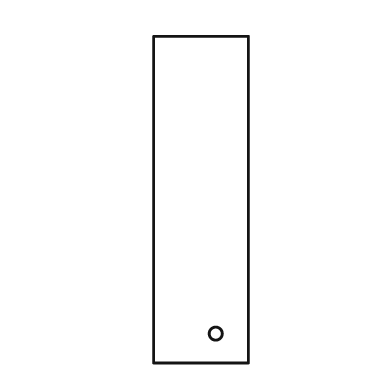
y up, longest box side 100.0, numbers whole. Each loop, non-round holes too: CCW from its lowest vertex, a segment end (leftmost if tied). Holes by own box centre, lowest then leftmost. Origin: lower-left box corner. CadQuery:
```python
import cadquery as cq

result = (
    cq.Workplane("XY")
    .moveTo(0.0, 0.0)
    .lineTo(29.0, 0.0)
    .lineTo(29.0, 100.0)
    .lineTo(0.0, 100.0)
    .close()
    .moveTo(19.0, 9.0)
    .circle(2.0)
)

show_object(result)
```